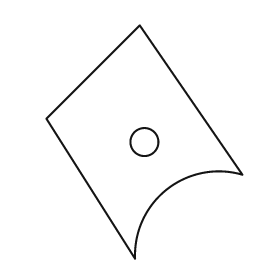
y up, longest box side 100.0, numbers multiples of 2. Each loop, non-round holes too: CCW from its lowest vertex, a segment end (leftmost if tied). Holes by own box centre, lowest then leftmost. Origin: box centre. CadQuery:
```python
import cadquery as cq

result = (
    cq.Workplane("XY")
    .moveTo(-4.0, -50.0)
    .threePointArc((10.0, -20.0), (42.0, -14.0))
    .lineTo(-2.0, 50.0)
    .lineTo(-42.0, 10.0)
    .close()
    .moveTo(0.0, 0.0)
    .circle(6.0)
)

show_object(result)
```